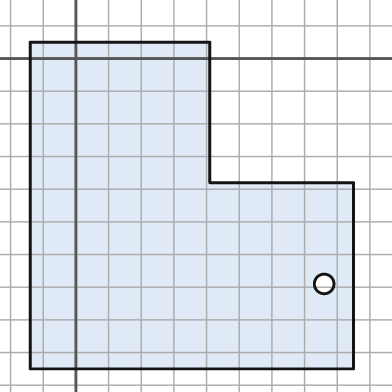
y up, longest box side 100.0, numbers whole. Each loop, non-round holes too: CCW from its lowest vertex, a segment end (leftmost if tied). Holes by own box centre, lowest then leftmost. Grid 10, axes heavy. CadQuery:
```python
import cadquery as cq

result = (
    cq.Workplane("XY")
    .moveTo(-14.0, -95.0)
    .lineTo(85.0, -95.0)
    .lineTo(85.0, -38.0)
    .lineTo(41.0, -38.0)
    .lineTo(41.0, 5.0)
    .lineTo(-14.0, 5.0)
    .close()
    .moveTo(76.0, -69.0)
    .circle(3.0)
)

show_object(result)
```